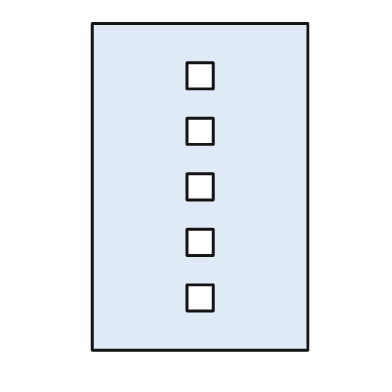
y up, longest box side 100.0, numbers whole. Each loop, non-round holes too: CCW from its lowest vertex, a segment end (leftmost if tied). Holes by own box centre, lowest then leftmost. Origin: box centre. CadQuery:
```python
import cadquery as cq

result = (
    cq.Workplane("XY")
    .moveTo(-33.0, -50.0)
    .lineTo(33.0, -50.0)
    .lineTo(33.0, 50.0)
    .lineTo(-33.0, 50.0)
    .close()
    .moveTo(-4.0, -38.0)
    .lineTo(4.0, -38.0)
    .lineTo(4.0, -30.0)
    .lineTo(-4.0, -30.0)
    .close()
    .moveTo(-4.0, -21.0)
    .lineTo(4.0, -21.0)
    .lineTo(4.0, -13.0)
    .lineTo(-4.0, -13.0)
    .close()
    .moveTo(-4.0, -4.0)
    .lineTo(4.0, -4.0)
    .lineTo(4.0, 4.0)
    .lineTo(-4.0, 4.0)
    .close()
    .moveTo(-4.0, 13.0)
    .lineTo(4.0, 13.0)
    .lineTo(4.0, 21.0)
    .lineTo(-4.0, 21.0)
    .close()
    .moveTo(-4.0, 30.0)
    .lineTo(4.0, 30.0)
    .lineTo(4.0, 38.0)
    .lineTo(-4.0, 38.0)
    .close()
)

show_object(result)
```